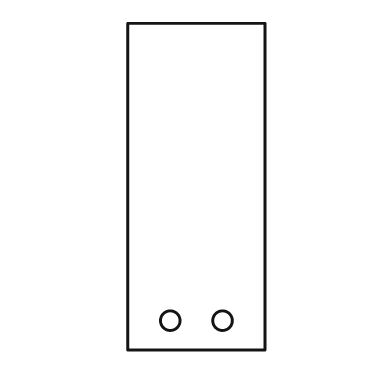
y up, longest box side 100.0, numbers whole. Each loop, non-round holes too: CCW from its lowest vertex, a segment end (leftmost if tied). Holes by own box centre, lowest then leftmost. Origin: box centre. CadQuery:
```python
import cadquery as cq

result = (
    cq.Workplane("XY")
    .moveTo(-21.0, -50.0)
    .lineTo(21.0, -50.0)
    .lineTo(21.0, 50.0)
    .lineTo(-21.0, 50.0)
    .close()
    .moveTo(-8.0, -41.0)
    .circle(3.0)
    .moveTo(8.0, -41.0)
    .circle(3.0)
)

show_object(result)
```